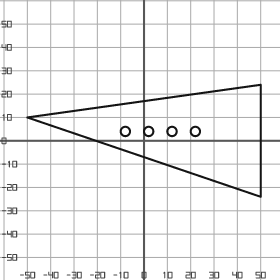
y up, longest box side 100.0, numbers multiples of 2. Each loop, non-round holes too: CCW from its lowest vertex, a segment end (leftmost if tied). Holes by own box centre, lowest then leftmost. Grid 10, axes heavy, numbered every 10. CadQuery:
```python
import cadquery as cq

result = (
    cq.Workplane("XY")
    .moveTo(50.0, -24.0)
    .lineTo(50.0, 24.0)
    .lineTo(-50.0, 10.0)
    .close()
    .moveTo(-8.0, 4.0)
    .circle(2.0)
    .moveTo(2.0, 4.0)
    .circle(2.0)
    .moveTo(12.0, 4.0)
    .circle(2.0)
    .moveTo(22.0, 4.0)
    .circle(2.0)
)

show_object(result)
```